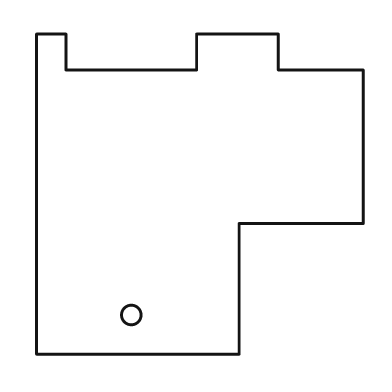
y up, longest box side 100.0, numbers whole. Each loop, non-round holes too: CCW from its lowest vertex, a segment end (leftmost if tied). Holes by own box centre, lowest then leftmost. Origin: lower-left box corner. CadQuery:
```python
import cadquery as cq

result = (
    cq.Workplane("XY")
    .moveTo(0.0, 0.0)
    .lineTo(62.0, 0.0)
    .lineTo(62.0, 40.0)
    .lineTo(100.0, 40.0)
    .lineTo(100.0, 87.0)
    .lineTo(74.0, 87.0)
    .lineTo(74.0, 98.0)
    .lineTo(49.0, 98.0)
    .lineTo(49.0, 87.0)
    .lineTo(9.0, 87.0)
    .lineTo(9.0, 98.0)
    .lineTo(0.0, 98.0)
    .close()
    .moveTo(29.0, 12.0)
    .circle(3.0)
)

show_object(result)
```